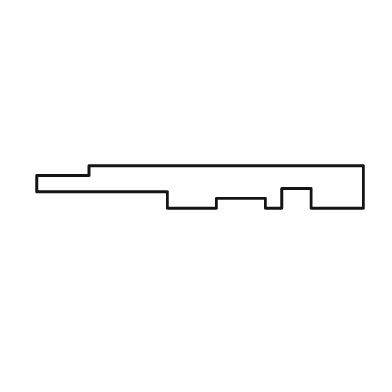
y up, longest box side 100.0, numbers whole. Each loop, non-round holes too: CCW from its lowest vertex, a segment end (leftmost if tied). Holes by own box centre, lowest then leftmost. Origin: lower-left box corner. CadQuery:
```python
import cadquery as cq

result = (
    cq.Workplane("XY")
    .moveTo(40.0, 0.0)
    .lineTo(55.0, 0.0)
    .lineTo(55.0, 3.0)
    .lineTo(70.0, 3.0)
    .lineTo(70.0, 0.0)
    .lineTo(75.0, 0.0)
    .lineTo(75.0, 6.0)
    .lineTo(84.0, 6.0)
    .lineTo(84.0, 0.0)
    .lineTo(100.0, 0.0)
    .lineTo(100.0, 13.0)
    .lineTo(16.0, 13.0)
    .lineTo(16.0, 10.0)
    .lineTo(0.0, 10.0)
    .lineTo(0.0, 5.0)
    .lineTo(40.0, 5.0)
    .close()
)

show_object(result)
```